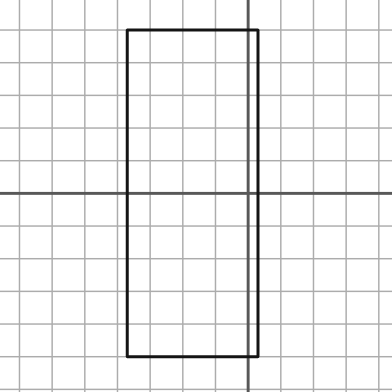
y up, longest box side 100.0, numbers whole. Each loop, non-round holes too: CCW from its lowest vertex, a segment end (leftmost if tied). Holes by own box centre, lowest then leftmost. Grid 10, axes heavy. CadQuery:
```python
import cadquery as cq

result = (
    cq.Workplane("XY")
    .moveTo(-37.0, -50.0)
    .lineTo(3.0, -50.0)
    .lineTo(3.0, 50.0)
    .lineTo(-37.0, 50.0)
    .close()
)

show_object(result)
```